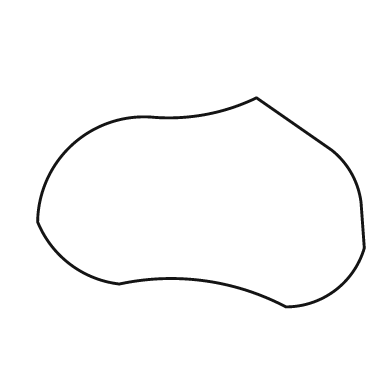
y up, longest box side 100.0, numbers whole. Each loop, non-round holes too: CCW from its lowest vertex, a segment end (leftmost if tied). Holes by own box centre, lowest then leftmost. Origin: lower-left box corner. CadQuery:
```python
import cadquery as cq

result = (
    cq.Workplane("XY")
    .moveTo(76.0, 0.0)
    .threePointArc((91.0, 5.0), (100.0, 18.0))
    .lineTo(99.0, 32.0)
    .threePointArc((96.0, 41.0), (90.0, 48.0))
    .lineTo(67.0, 64.0)
    .threePointArc((52.0, 59.0), (36.0, 58.0))
    .threePointArc((11.0, 50.0), (0.0, 26.0))
    .threePointArc((10.0, 13.0), (25.0, 7.0))
    .threePointArc((51.0, 8.0), (76.0, 0.0))
    .close()
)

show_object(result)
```